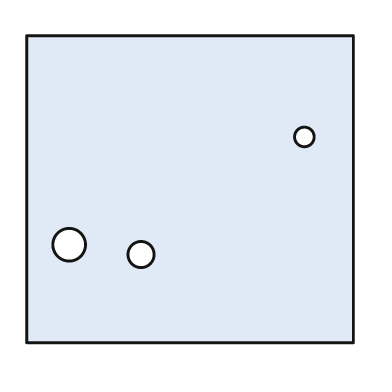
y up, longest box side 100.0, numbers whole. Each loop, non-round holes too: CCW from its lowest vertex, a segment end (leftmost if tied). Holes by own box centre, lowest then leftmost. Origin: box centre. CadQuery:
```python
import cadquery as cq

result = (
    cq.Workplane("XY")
    .moveTo(-50.0, -47.0)
    .lineTo(50.0, -47.0)
    .lineTo(50.0, 47.0)
    .lineTo(-50.0, 47.0)
    .close()
    .moveTo(-15.0, -20.0)
    .circle(4.0)
    .moveTo(-37.0, -17.0)
    .circle(5.0)
    .moveTo(35.0, 16.0)
    .circle(3.0)
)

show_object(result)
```